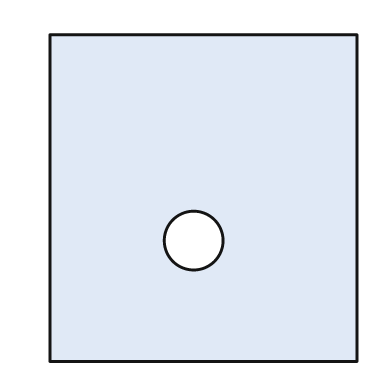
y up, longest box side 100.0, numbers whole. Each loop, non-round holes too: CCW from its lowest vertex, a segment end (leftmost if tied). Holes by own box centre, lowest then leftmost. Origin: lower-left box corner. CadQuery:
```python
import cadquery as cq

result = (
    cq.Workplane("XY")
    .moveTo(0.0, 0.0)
    .lineTo(94.0, 0.0)
    .lineTo(94.0, 100.0)
    .lineTo(0.0, 100.0)
    .close()
    .moveTo(44.0, 37.0)
    .circle(9.0)
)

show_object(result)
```